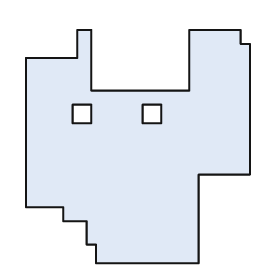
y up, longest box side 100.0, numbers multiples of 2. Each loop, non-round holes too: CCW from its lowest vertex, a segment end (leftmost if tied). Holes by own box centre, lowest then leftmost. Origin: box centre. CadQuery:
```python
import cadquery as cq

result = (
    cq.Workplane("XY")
    .moveTo(-18.0, -50.0)
    .lineTo(26.0, -50.0)
    .lineTo(26.0, -12.0)
    .lineTo(48.0, -12.0)
    .lineTo(48.0, 44.0)
    .lineTo(44.0, 44.0)
    .lineTo(44.0, 50.0)
    .lineTo(22.0, 50.0)
    .lineTo(22.0, 24.0)
    .lineTo(-20.0, 24.0)
    .lineTo(-20.0, 50.0)
    .lineTo(-26.0, 50.0)
    .lineTo(-26.0, 38.0)
    .lineTo(-48.0, 38.0)
    .lineTo(-48.0, -26.0)
    .lineTo(-32.0, -26.0)
    .lineTo(-32.0, -32.0)
    .lineTo(-22.0, -32.0)
    .lineTo(-22.0, -42.0)
    .lineTo(-18.0, -42.0)
    .close()
    .moveTo(-28.0, 10.0)
    .lineTo(-20.0, 10.0)
    .lineTo(-20.0, 18.0)
    .lineTo(-28.0, 18.0)
    .close()
    .moveTo(2.0, 10.0)
    .lineTo(10.0, 10.0)
    .lineTo(10.0, 18.0)
    .lineTo(2.0, 18.0)
    .close()
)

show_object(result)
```